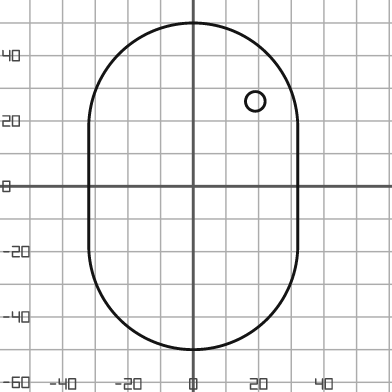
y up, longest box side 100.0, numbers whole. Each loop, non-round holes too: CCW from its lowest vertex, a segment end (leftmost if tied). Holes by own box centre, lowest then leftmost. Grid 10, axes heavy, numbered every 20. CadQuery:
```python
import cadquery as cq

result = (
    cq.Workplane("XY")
    .moveTo(-32.0, -18.0)
    .threePointArc((0.0, -50.0), (32.0, -18.0))
    .lineTo(32.0, 18.0)
    .threePointArc((0.0, 50.0), (-32.0, 18.0))
    .close()
    .moveTo(19.0, 26.0)
    .circle(3.0)
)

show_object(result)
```